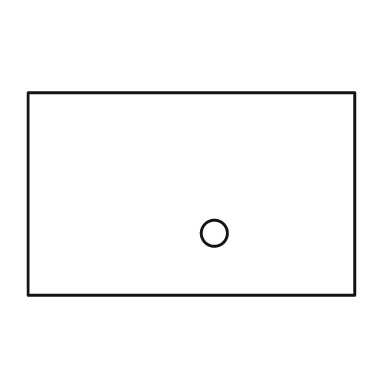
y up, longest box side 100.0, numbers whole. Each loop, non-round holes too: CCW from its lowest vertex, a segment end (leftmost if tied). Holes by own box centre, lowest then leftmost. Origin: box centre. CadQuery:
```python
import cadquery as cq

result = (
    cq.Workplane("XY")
    .moveTo(-50.0, -31.0)
    .lineTo(50.0, -31.0)
    .lineTo(50.0, 31.0)
    .lineTo(-50.0, 31.0)
    .close()
    .moveTo(7.0, -12.0)
    .circle(4.0)
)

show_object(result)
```